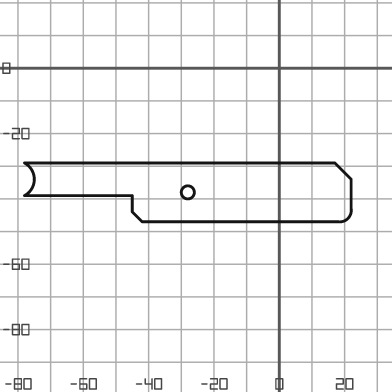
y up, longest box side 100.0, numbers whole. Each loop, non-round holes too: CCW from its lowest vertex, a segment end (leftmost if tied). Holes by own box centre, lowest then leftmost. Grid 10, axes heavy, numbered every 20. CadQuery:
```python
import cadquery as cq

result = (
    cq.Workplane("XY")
    .moveTo(-42.0, -47.0)
    .lineTo(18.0, -47.0)
    .threePointArc((21.0, -46.0), (22.0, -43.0))
    .lineTo(22.0, -34.0)
    .lineTo(17.0, -29.0)
    .lineTo(-78.0, -29.0)
    .threePointArc((-75.0, -34.0), (-78.0, -39.0))
    .lineTo(-45.0, -39.0)
    .lineTo(-45.0, -44.0)
    .close()
    .moveTo(-28.0, -38.0)
    .circle(2.0)
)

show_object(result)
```